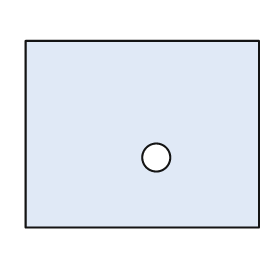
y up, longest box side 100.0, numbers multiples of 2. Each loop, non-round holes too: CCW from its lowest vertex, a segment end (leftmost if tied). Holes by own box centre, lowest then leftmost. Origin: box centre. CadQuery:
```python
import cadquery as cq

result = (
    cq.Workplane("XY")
    .moveTo(-50.0, -40.0)
    .lineTo(50.0, -40.0)
    .lineTo(50.0, 40.0)
    .lineTo(-50.0, 40.0)
    .close()
    .moveTo(6.0, -10.0)
    .circle(6.0)
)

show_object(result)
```